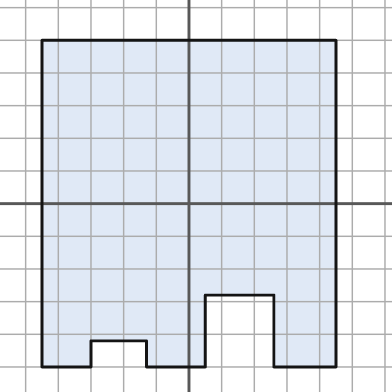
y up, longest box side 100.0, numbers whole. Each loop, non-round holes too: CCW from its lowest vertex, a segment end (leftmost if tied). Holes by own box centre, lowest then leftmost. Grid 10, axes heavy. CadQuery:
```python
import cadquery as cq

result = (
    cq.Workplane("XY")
    .moveTo(-45.0, -50.0)
    .lineTo(-30.0, -50.0)
    .lineTo(-30.0, -42.0)
    .lineTo(-13.0, -42.0)
    .lineTo(-13.0, -50.0)
    .lineTo(5.0, -50.0)
    .lineTo(5.0, -28.0)
    .lineTo(26.0, -28.0)
    .lineTo(26.0, -50.0)
    .lineTo(45.0, -50.0)
    .lineTo(45.0, 50.0)
    .lineTo(-45.0, 50.0)
    .close()
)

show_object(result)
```